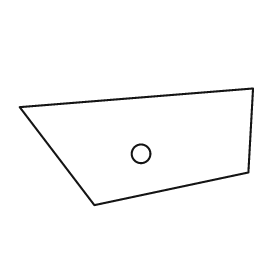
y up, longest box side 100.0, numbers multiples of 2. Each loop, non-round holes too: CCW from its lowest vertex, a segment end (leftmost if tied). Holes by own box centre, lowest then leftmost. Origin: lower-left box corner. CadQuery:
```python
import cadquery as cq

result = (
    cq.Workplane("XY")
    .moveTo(32.0, 0.0)
    .lineTo(98.0, 14.0)
    .lineTo(100.0, 50.0)
    .lineTo(0.0, 42.0)
    .close()
    .moveTo(52.0, 22.0)
    .circle(4.0)
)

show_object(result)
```